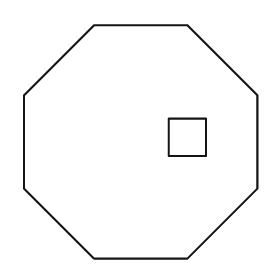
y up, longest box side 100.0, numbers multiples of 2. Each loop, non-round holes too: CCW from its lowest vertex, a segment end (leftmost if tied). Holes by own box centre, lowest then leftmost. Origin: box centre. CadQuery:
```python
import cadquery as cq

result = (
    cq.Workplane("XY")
    .moveTo(-20.0, -50.0)
    .lineTo(20.0, -50.0)
    .lineTo(50.0, -20.0)
    .lineTo(50.0, 20.0)
    .lineTo(20.0, 50.0)
    .lineTo(-20.0, 50.0)
    .lineTo(-50.0, 20.0)
    .lineTo(-50.0, -20.0)
    .close()
    .moveTo(12.0, -6.0)
    .lineTo(28.0, -6.0)
    .lineTo(28.0, 10.0)
    .lineTo(12.0, 10.0)
    .close()
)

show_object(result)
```